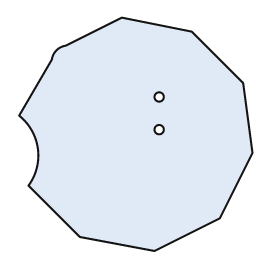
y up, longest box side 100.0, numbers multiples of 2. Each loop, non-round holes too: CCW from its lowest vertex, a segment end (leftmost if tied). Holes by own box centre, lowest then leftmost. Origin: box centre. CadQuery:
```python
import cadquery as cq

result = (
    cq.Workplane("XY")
    .moveTo(8.0, -50.0)
    .lineTo(36.0, -36.0)
    .lineTo(50.0, -8.0)
    .lineTo(46.0, 22.0)
    .lineTo(24.0, 44.0)
    .lineTo(-6.0, 50.0)
    .lineTo(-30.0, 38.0)
    .threePointArc((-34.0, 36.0), (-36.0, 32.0))
    .lineTo(-50.0, 8.0)
    .threePointArc((-42.0, -6.0), (-46.0, -22.0))
    .lineTo(-24.0, -44.0)
    .close()
    .moveTo(10.0, 2.0)
    .circle(2.0)
    .moveTo(10.0, 16.0)
    .circle(2.0)
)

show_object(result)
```